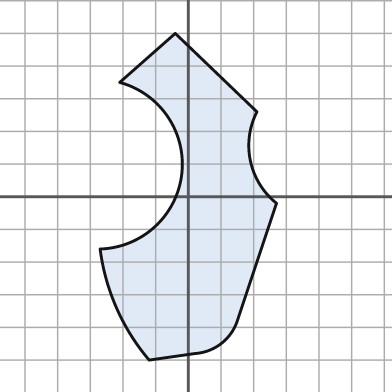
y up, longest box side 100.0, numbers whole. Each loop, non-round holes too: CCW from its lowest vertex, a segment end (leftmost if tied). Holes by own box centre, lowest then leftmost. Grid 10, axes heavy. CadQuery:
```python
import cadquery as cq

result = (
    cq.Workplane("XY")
    .moveTo(-12.0, -50.0)
    .lineTo(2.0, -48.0)
    .threePointArc((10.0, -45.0), (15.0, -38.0))
    .lineTo(27.0, -2.0)
    .threePointArc((19.0, 11.0), (21.0, 26.0))
    .lineTo(-4.0, 50.0)
    .lineTo(-21.0, 35.0)
    .threePointArc((-2.0, 7.0), (-27.0, -16.0))
    .threePointArc((-22.0, -34.0), (-12.0, -50.0))
    .close()
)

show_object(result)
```